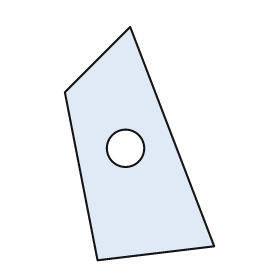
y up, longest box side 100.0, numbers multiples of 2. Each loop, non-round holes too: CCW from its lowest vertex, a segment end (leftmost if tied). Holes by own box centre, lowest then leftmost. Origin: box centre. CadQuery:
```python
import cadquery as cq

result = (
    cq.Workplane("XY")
    .moveTo(-18.0, -50.0)
    .lineTo(32.0, -44.0)
    .lineTo(-4.0, 50.0)
    .lineTo(-32.0, 22.0)
    .close()
    .moveTo(-6.0, -2.0)
    .circle(8.0)
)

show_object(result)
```